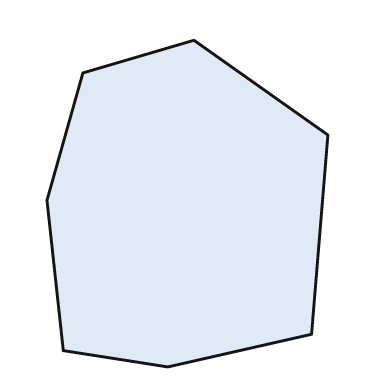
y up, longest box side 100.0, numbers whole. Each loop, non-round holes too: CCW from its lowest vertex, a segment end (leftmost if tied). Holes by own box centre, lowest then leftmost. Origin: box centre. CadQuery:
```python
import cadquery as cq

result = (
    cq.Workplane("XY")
    .moveTo(-6.0, -50.0)
    .lineTo(38.0, -40.0)
    .lineTo(43.0, 21.0)
    .lineTo(2.0, 50.0)
    .lineTo(-32.0, 40.0)
    .lineTo(-43.0, 1.0)
    .lineTo(-38.0, -45.0)
    .close()
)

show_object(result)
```